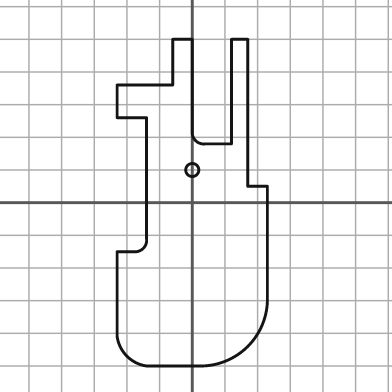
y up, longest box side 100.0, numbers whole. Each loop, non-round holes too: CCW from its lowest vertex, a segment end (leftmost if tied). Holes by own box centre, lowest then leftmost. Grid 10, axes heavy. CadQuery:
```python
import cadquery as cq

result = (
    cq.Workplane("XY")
    .moveTo(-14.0, -50.0)
    .lineTo(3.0, -50.0)
    .threePointArc((17.0, -44.0), (23.0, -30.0))
    .lineTo(23.0, 5.0)
    .lineTo(17.0, 5.0)
    .lineTo(17.0, 50.0)
    .lineTo(12.0, 50.0)
    .lineTo(12.0, 18.0)
    .lineTo(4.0, 18.0)
    .threePointArc((1.0, 19.0), (0.0, 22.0))
    .lineTo(0.0, 50.0)
    .lineTo(-6.0, 50.0)
    .lineTo(-6.0, 36.0)
    .lineTo(-23.0, 36.0)
    .lineTo(-23.0, 26.0)
    .lineTo(-14.0, 26.0)
    .lineTo(-14.0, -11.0)
    .threePointArc((-15.0, -14.0), (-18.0, -15.0))
    .lineTo(-23.0, -15.0)
    .lineTo(-23.0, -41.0)
    .threePointArc((-20.0, -47.0), (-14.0, -50.0))
    .close()
    .moveTo(0.0, 10.0)
    .circle(2.0)
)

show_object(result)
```